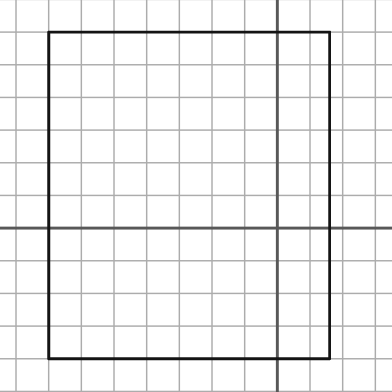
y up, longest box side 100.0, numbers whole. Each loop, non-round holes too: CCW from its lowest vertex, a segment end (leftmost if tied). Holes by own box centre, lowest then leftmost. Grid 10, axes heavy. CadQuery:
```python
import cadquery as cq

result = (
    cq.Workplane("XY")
    .moveTo(-70.0, -40.0)
    .lineTo(16.0, -40.0)
    .lineTo(16.0, 60.0)
    .lineTo(-70.0, 60.0)
    .close()
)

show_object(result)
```